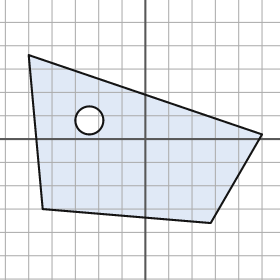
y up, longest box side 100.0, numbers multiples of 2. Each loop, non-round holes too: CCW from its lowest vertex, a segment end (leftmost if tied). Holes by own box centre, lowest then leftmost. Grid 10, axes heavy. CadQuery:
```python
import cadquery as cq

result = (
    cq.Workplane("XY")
    .moveTo(28.0, -36.0)
    .lineTo(50.0, 2.0)
    .lineTo(-50.0, 36.0)
    .lineTo(-44.0, -30.0)
    .close()
    .moveTo(-24.0, 8.0)
    .circle(6.0)
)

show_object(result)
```